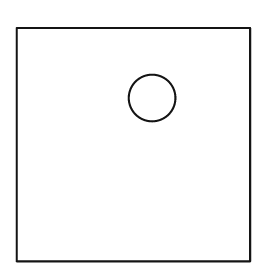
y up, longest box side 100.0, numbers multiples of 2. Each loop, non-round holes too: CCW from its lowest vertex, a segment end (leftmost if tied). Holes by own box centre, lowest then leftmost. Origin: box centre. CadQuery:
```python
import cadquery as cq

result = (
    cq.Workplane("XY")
    .moveTo(-50.0, -50.0)
    .lineTo(50.0, -50.0)
    .lineTo(50.0, 50.0)
    .lineTo(-50.0, 50.0)
    .close()
    .moveTo(8.0, 20.0)
    .circle(10.0)
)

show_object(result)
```